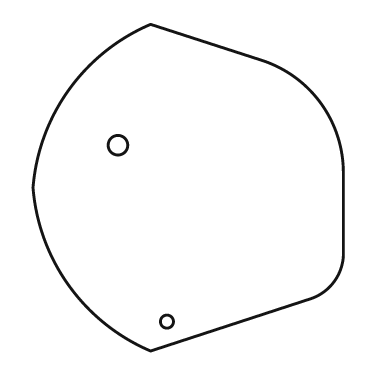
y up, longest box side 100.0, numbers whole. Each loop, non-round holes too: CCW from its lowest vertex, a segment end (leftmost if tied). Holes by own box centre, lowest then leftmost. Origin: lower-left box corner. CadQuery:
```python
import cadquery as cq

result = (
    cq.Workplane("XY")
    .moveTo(36.0, 0.0)
    .lineTo(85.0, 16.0)
    .threePointArc((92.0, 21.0), (95.0, 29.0))
    .lineTo(95.0, 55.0)
    .threePointArc((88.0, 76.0), (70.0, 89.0))
    .lineTo(36.0, 100.0)
    .threePointArc((11.0, 80.0), (0.0, 50.0))
    .threePointArc((11.0, 20.0), (36.0, 0.0))
    .close()
    .moveTo(41.0, 9.0)
    .circle(2.0)
    .moveTo(26.0, 63.0)
    .circle(3.0)
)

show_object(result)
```